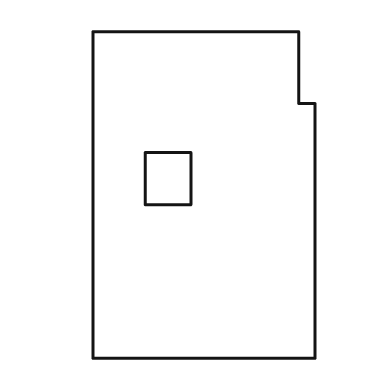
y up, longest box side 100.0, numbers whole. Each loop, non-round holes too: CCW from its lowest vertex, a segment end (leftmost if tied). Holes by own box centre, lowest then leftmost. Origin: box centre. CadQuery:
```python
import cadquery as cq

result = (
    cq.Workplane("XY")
    .moveTo(-34.0, -50.0)
    .lineTo(34.0, -50.0)
    .lineTo(34.0, 28.0)
    .lineTo(29.0, 28.0)
    .lineTo(29.0, 50.0)
    .lineTo(-34.0, 50.0)
    .close()
    .moveTo(-18.0, -3.0)
    .lineTo(-4.0, -3.0)
    .lineTo(-4.0, 13.0)
    .lineTo(-18.0, 13.0)
    .close()
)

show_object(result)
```